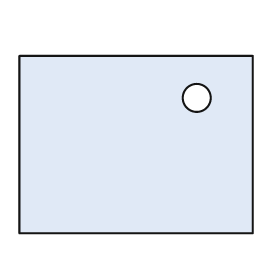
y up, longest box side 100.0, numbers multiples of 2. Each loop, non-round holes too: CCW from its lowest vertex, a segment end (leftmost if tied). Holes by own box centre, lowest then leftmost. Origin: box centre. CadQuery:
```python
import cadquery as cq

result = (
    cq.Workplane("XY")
    .moveTo(-50.0, -38.0)
    .lineTo(50.0, -38.0)
    .lineTo(50.0, 38.0)
    .lineTo(-50.0, 38.0)
    .close()
    .moveTo(26.0, 20.0)
    .circle(6.0)
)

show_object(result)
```